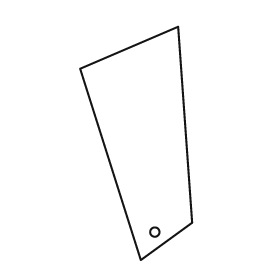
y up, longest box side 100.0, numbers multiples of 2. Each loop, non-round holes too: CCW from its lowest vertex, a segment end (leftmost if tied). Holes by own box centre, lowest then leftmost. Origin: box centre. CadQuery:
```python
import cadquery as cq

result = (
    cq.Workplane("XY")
    .moveTo(2.0, -50.0)
    .lineTo(24.0, -34.0)
    .lineTo(18.0, 50.0)
    .lineTo(-24.0, 32.0)
    .close()
    .moveTo(8.0, -38.0)
    .circle(2.0)
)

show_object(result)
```